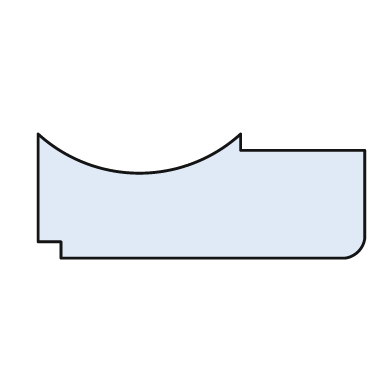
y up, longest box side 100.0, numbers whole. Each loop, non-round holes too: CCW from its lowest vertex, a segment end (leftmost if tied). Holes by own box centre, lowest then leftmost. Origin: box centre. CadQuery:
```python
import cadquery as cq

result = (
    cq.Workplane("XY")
    .moveTo(-43.0, -19.0)
    .lineTo(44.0, -19.0)
    .threePointArc((48.0, -17.0), (50.0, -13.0))
    .lineTo(50.0, 14.0)
    .lineTo(12.0, 14.0)
    .lineTo(12.0, 19.0)
    .threePointArc((-19.0, 7.0), (-50.0, 19.0))
    .lineTo(-50.0, -14.0)
    .lineTo(-43.0, -14.0)
    .close()
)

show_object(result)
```